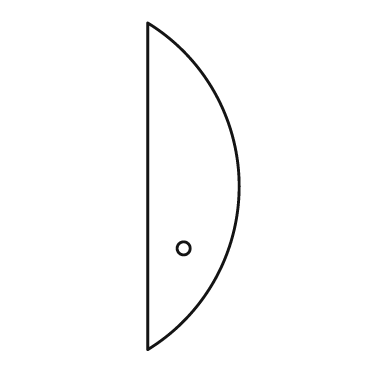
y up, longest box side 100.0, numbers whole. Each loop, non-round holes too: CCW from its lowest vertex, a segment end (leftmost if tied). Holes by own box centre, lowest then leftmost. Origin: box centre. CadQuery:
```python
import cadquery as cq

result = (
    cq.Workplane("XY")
    .moveTo(-14.0, -50.0)
    .threePointArc((14.0, 0.0), (-14.0, 50.0))
    .close()
    .moveTo(-3.0, -19.0)
    .circle(2.0)
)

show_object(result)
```